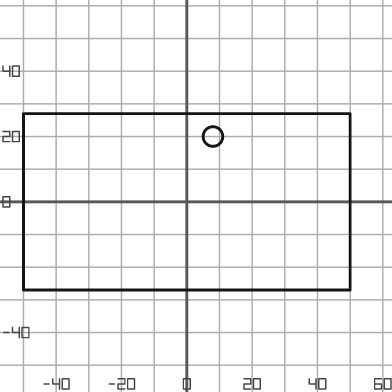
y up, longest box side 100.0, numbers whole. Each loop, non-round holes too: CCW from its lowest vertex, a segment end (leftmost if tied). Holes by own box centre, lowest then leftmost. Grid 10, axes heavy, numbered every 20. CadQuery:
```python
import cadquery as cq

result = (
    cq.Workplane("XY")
    .moveTo(-50.0, -27.0)
    .lineTo(50.0, -27.0)
    .lineTo(50.0, 27.0)
    .lineTo(-50.0, 27.0)
    .close()
    .moveTo(8.0, 20.0)
    .circle(3.0)
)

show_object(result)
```